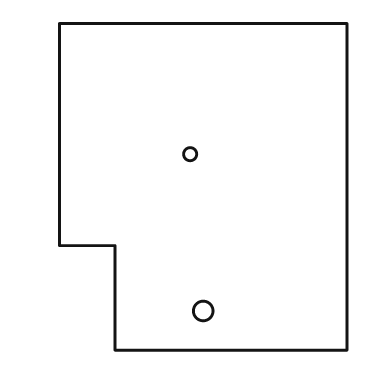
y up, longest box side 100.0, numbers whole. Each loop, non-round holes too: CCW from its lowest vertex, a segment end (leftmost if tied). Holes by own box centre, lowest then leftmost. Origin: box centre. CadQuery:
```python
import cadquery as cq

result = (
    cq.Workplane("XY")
    .moveTo(-27.0, -50.0)
    .lineTo(44.0, -50.0)
    .lineTo(44.0, 50.0)
    .lineTo(-44.0, 50.0)
    .lineTo(-44.0, -18.0)
    .lineTo(-27.0, -18.0)
    .close()
    .moveTo(0.0, -38.0)
    .circle(3.0)
    .moveTo(-4.0, 10.0)
    .circle(2.0)
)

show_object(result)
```